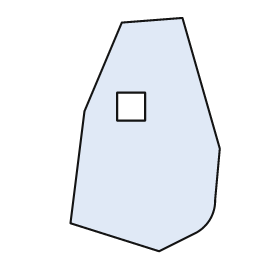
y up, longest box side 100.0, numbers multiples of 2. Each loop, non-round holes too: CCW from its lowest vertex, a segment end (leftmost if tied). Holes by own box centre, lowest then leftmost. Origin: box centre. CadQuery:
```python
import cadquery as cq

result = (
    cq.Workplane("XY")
    .moveTo(6.0, -50.0)
    .lineTo(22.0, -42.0)
    .threePointArc((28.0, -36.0), (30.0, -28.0))
    .lineTo(32.0, -6.0)
    .lineTo(16.0, 50.0)
    .lineTo(-10.0, 48.0)
    .lineTo(-26.0, 10.0)
    .lineTo(-32.0, -38.0)
    .close()
    .moveTo(-12.0, 6.0)
    .lineTo(0.0, 6.0)
    .lineTo(0.0, 18.0)
    .lineTo(-12.0, 18.0)
    .close()
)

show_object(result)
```